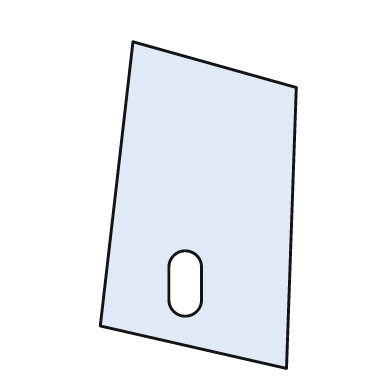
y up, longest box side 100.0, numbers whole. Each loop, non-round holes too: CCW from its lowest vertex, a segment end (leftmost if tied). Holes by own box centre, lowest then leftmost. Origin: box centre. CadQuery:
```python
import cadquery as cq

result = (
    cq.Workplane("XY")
    .moveTo(27.0, -50.0)
    .lineTo(30.0, 36.0)
    .lineTo(-20.0, 50.0)
    .lineTo(-30.0, -37.0)
    .close()
    .moveTo(-9.0, -29.0)
    .threePointArc((-4.0, -34.0), (1.0, -29.0))
    .lineTo(1.0, -19.0)
    .threePointArc((-4.0, -14.0), (-9.0, -19.0))
    .close()
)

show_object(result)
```